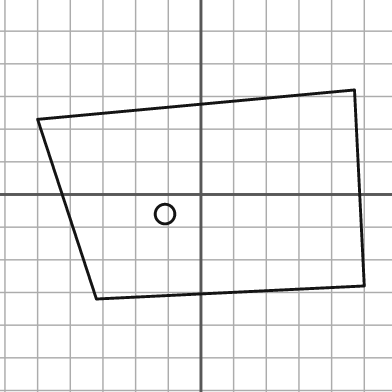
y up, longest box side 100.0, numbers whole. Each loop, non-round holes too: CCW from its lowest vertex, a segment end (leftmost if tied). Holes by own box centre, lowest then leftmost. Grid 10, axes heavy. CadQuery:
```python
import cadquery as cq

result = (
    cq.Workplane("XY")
    .moveTo(-32.0, -32.0)
    .lineTo(50.0, -28.0)
    .lineTo(47.0, 32.0)
    .lineTo(-50.0, 23.0)
    .close()
    .moveTo(-11.0, -6.0)
    .circle(3.0)
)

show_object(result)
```